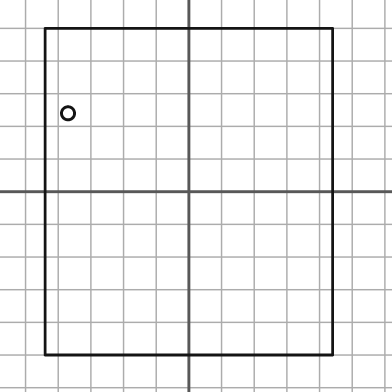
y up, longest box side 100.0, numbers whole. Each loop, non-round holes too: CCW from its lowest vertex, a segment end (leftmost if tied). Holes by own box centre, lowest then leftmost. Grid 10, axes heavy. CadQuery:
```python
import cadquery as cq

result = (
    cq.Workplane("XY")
    .moveTo(-44.0, -50.0)
    .lineTo(44.0, -50.0)
    .lineTo(44.0, 50.0)
    .lineTo(-44.0, 50.0)
    .close()
    .moveTo(-37.0, 24.0)
    .circle(2.0)
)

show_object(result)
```